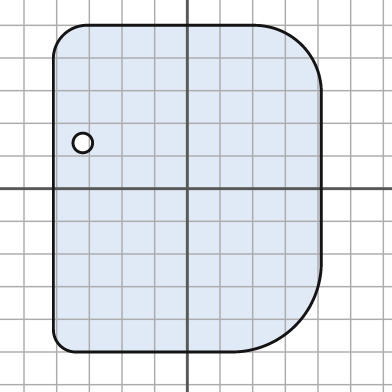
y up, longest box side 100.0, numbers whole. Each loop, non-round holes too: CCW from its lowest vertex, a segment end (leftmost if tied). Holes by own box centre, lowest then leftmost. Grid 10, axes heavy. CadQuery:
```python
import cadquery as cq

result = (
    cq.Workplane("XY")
    .moveTo(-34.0, -50.0)
    .lineTo(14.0, -50.0)
    .threePointArc((33.0, -42.0), (41.0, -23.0))
    .lineTo(41.0, 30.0)
    .threePointArc((35.0, 44.0), (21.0, 50.0))
    .lineTo(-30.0, 50.0)
    .threePointArc((-38.0, 47.0), (-41.0, 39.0))
    .lineTo(-41.0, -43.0)
    .threePointArc((-39.0, -48.0), (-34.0, -50.0))
    .close()
    .moveTo(-32.0, 14.0)
    .circle(3.0)
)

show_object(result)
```